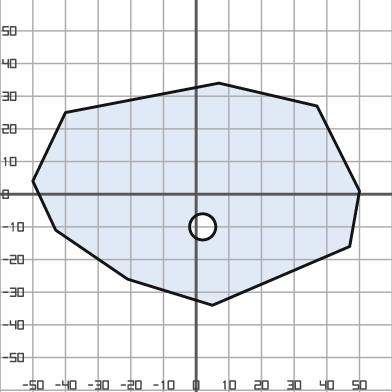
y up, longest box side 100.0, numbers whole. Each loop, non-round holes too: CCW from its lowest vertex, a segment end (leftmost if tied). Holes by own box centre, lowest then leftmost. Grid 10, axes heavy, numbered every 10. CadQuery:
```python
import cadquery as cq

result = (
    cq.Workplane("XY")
    .moveTo(5.0, -34.0)
    .lineTo(47.0, -16.0)
    .lineTo(50.0, 1.0)
    .lineTo(37.0, 27.0)
    .lineTo(7.0, 34.0)
    .lineTo(-40.0, 25.0)
    .lineTo(-50.0, 4.0)
    .lineTo(-43.0, -11.0)
    .lineTo(-21.0, -26.0)
    .close()
    .moveTo(2.0, -10.0)
    .circle(4.0)
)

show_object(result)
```